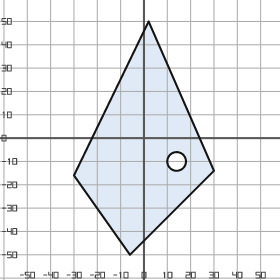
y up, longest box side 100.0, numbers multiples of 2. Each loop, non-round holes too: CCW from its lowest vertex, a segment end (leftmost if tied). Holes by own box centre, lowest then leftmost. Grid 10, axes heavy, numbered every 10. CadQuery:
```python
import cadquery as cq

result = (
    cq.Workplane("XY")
    .moveTo(-6.0, -50.0)
    .lineTo(30.0, -14.0)
    .lineTo(2.0, 50.0)
    .lineTo(-30.0, -16.0)
    .close()
    .moveTo(14.0, -10.0)
    .circle(4.0)
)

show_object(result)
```